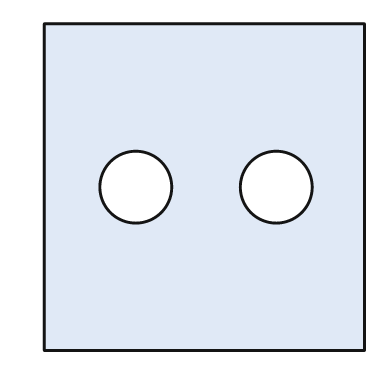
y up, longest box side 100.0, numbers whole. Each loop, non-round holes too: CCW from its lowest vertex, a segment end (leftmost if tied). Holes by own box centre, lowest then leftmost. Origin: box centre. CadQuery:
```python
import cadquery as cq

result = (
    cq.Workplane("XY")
    .moveTo(-49.0, -50.0)
    .lineTo(49.0, -50.0)
    .lineTo(49.0, 50.0)
    .lineTo(-49.0, 50.0)
    .close()
    .moveTo(-21.0, 0.0)
    .circle(11.0)
    .moveTo(22.0, 0.0)
    .circle(11.0)
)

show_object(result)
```